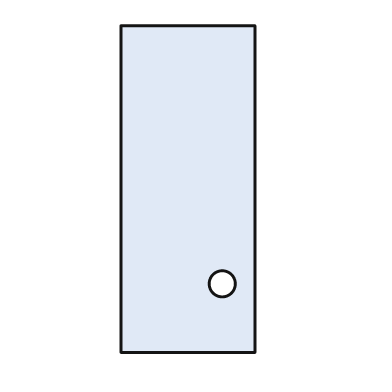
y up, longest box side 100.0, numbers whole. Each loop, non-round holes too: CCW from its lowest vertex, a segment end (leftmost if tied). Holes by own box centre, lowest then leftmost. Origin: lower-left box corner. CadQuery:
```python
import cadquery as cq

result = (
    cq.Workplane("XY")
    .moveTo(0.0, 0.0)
    .lineTo(41.0, 0.0)
    .lineTo(41.0, 100.0)
    .lineTo(0.0, 100.0)
    .close()
    .moveTo(31.0, 21.0)
    .circle(4.0)
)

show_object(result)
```